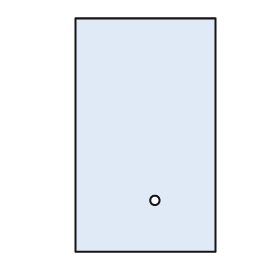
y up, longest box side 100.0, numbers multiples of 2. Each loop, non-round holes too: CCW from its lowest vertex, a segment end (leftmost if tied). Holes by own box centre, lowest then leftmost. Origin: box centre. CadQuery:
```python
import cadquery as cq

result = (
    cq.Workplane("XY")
    .moveTo(-30.0, -50.0)
    .lineTo(30.0, -50.0)
    .lineTo(30.0, 50.0)
    .lineTo(-30.0, 50.0)
    .close()
    .moveTo(4.0, -28.0)
    .circle(2.0)
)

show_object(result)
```